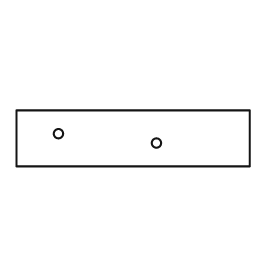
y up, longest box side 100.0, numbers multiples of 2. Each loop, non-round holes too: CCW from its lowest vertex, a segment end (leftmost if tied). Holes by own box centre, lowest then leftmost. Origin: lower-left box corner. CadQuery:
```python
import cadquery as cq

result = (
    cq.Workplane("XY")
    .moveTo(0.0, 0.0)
    .lineTo(100.0, 0.0)
    .lineTo(100.0, 24.0)
    .lineTo(0.0, 24.0)
    .close()
    .moveTo(60.0, 10.0)
    .circle(2.0)
    .moveTo(18.0, 14.0)
    .circle(2.0)
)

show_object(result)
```